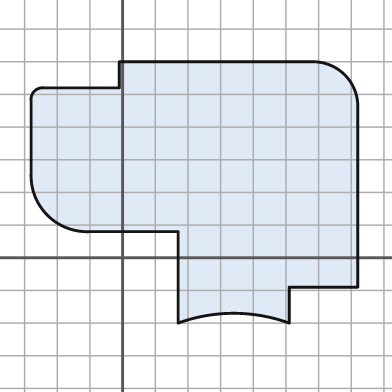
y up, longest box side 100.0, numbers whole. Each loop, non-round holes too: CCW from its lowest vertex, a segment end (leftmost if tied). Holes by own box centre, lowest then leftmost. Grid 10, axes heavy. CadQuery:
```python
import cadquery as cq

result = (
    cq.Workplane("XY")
    .moveTo(17.0, -20.0)
    .threePointArc((34.0, -17.0), (51.0, -20.0))
    .lineTo(51.0, -9.0)
    .lineTo(72.0, -9.0)
    .lineTo(72.0, 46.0)
    .threePointArc((68.0, 56.0), (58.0, 60.0))
    .lineTo(-1.0, 60.0)
    .lineTo(-1.0, 52.0)
    .lineTo(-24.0, 52.0)
    .threePointArc((-27.0, 51.0), (-28.0, 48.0))
    .lineTo(-28.0, 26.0)
    .threePointArc((-23.0, 13.0), (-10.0, 8.0))
    .lineTo(17.0, 8.0)
    .close()
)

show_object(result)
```